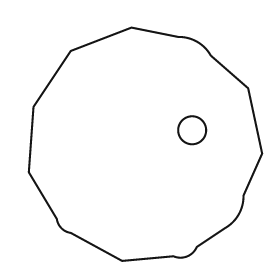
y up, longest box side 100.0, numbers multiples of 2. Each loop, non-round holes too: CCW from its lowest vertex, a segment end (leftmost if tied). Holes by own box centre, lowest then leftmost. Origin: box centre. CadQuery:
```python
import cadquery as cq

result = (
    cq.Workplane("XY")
    .moveTo(-10.0, -50.0)
    .lineTo(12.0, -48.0)
    .threePointArc((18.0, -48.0), (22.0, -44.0))
    .lineTo(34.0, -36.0)
    .threePointArc((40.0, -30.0), (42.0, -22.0))
    .lineTo(50.0, -4.0)
    .lineTo(44.0, 24.0)
    .lineTo(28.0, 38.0)
    .threePointArc((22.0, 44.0), (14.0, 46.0))
    .lineTo(-6.0, 50.0)
    .lineTo(-32.0, 40.0)
    .lineTo(-48.0, 16.0)
    .lineTo(-50.0, -12.0)
    .lineTo(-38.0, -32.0)
    .threePointArc((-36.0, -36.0), (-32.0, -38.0))
    .close()
    .moveTo(20.0, 6.0)
    .circle(6.0)
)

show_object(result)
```